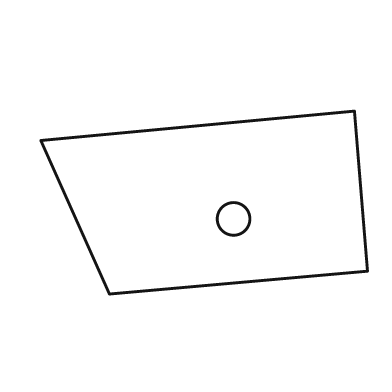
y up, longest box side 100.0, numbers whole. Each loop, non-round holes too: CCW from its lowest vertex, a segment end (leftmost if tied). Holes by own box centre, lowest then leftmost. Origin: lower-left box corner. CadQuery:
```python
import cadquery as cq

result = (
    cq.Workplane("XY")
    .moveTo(21.0, 0.0)
    .lineTo(100.0, 7.0)
    .lineTo(96.0, 56.0)
    .lineTo(0.0, 47.0)
    .close()
    .moveTo(59.0, 23.0)
    .circle(5.0)
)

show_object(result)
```